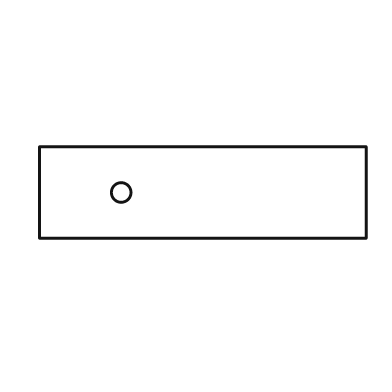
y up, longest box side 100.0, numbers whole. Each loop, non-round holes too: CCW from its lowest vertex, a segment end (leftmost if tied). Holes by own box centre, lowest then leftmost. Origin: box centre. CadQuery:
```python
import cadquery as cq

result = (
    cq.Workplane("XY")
    .moveTo(-50.0, -14.0)
    .lineTo(50.0, -14.0)
    .lineTo(50.0, 14.0)
    .lineTo(-50.0, 14.0)
    .close()
    .moveTo(-25.0, 0.0)
    .circle(3.0)
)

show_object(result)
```